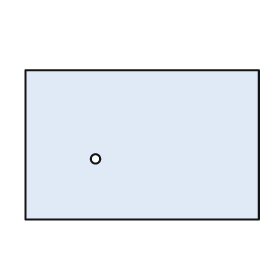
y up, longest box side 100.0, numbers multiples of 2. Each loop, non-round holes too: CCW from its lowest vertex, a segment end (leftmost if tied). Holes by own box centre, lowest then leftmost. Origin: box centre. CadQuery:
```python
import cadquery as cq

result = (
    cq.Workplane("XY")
    .moveTo(-50.0, -32.0)
    .lineTo(50.0, -32.0)
    .lineTo(50.0, 32.0)
    .lineTo(-50.0, 32.0)
    .close()
    .moveTo(-20.0, -6.0)
    .circle(2.0)
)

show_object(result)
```